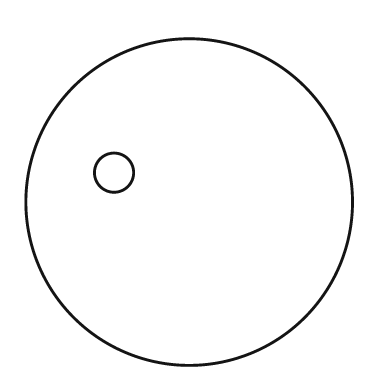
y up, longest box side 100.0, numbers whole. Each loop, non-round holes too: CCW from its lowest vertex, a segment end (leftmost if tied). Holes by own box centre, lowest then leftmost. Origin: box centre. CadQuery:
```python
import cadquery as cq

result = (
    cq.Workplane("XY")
    .moveTo(0.0, 0.0)
    .circle(50.0)
    .moveTo(-23.0, 9.0)
    .circle(6.0)
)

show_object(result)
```